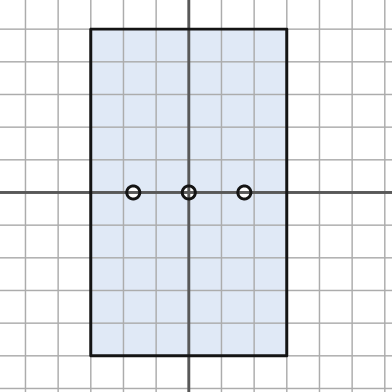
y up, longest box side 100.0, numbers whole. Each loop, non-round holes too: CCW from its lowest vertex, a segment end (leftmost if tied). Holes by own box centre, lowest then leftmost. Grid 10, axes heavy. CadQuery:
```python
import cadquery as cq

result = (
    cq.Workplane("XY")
    .moveTo(-30.0, -50.0)
    .lineTo(30.0, -50.0)
    .lineTo(30.0, 50.0)
    .lineTo(-30.0, 50.0)
    .close()
    .moveTo(-17.0, 0.0)
    .circle(2.0)
    .moveTo(0.0, 0.0)
    .circle(2.0)
    .moveTo(17.0, 0.0)
    .circle(2.0)
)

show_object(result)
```